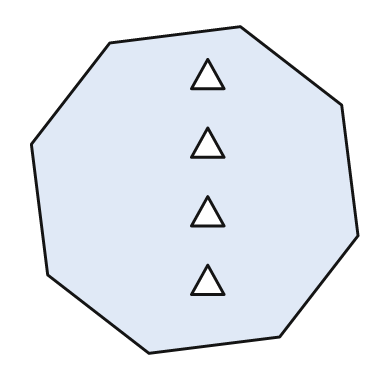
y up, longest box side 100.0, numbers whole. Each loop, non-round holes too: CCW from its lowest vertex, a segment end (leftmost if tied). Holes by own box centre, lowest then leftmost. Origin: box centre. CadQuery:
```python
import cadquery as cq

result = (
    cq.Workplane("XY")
    .moveTo(-14.0, -50.0)
    .lineTo(26.0, -45.0)
    .lineTo(50.0, -14.0)
    .lineTo(45.0, 26.0)
    .lineTo(14.0, 50.0)
    .lineTo(-26.0, 45.0)
    .lineTo(-50.0, 14.0)
    .lineTo(-45.0, -26.0)
    .close()
    .moveTo(-1.0, -32.0)
    .lineTo(9.0, -32.0)
    .lineTo(4.0, -23.0)
    .close()
    .moveTo(-1.0, -11.0)
    .lineTo(9.0, -11.0)
    .lineTo(4.0, -2.0)
    .close()
    .moveTo(-1.0, 10.0)
    .lineTo(9.0, 10.0)
    .lineTo(4.0, 19.0)
    .close()
    .moveTo(-1.0, 31.0)
    .lineTo(9.0, 31.0)
    .lineTo(4.0, 40.0)
    .close()
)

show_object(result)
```